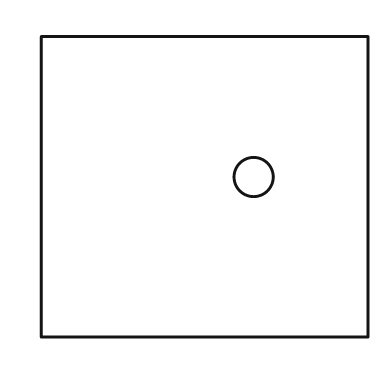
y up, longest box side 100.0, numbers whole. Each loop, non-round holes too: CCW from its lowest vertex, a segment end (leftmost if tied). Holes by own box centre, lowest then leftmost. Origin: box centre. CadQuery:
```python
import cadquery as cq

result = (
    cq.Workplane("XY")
    .moveTo(-50.0, -46.0)
    .lineTo(50.0, -46.0)
    .lineTo(50.0, 46.0)
    .lineTo(-50.0, 46.0)
    .close()
    .moveTo(15.0, 3.0)
    .circle(6.0)
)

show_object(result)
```